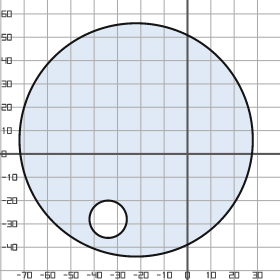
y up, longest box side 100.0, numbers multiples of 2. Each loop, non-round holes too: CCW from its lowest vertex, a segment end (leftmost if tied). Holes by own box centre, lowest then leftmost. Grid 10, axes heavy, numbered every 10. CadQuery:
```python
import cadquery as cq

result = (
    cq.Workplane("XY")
    .moveTo(-22.0, 6.0)
    .circle(50.0)
    .moveTo(-34.0, -28.0)
    .circle(8.0)
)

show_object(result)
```